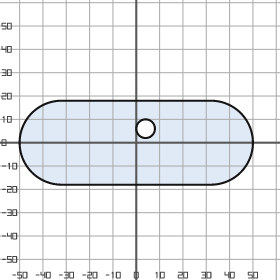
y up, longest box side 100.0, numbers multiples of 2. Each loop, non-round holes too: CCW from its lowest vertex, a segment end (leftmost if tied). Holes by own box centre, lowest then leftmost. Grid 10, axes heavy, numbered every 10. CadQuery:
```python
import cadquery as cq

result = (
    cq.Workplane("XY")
    .moveTo(-32.0, -18.0)
    .lineTo(32.0, -18.0)
    .threePointArc((50.0, 0.0), (32.0, 18.0))
    .lineTo(-32.0, 18.0)
    .threePointArc((-50.0, 0.0), (-32.0, -18.0))
    .close()
    .moveTo(4.0, 6.0)
    .circle(4.0)
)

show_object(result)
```